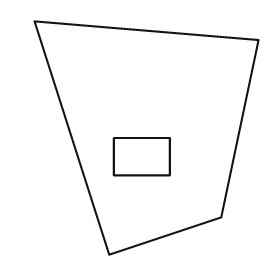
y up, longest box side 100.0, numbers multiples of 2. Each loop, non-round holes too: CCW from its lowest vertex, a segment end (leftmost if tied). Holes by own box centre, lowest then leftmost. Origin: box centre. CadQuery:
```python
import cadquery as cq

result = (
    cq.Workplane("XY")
    .moveTo(-16.0, -50.0)
    .lineTo(32.0, -34.0)
    .lineTo(48.0, 42.0)
    .lineTo(-48.0, 50.0)
    .close()
    .moveTo(-14.0, -16.0)
    .lineTo(10.0, -16.0)
    .lineTo(10.0, 0.0)
    .lineTo(-14.0, 0.0)
    .close()
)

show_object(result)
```